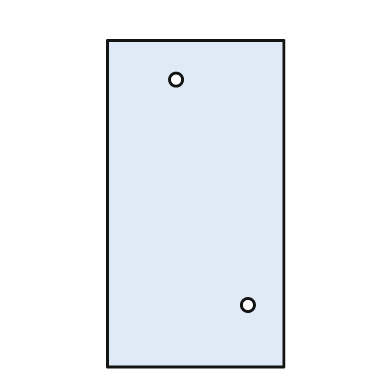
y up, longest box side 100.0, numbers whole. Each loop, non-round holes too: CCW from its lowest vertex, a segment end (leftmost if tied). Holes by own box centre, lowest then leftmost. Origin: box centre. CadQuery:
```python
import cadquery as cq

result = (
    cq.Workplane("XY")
    .moveTo(-27.0, -50.0)
    .lineTo(27.0, -50.0)
    .lineTo(27.0, 50.0)
    .lineTo(-27.0, 50.0)
    .close()
    .moveTo(16.0, -31.0)
    .circle(2.0)
    .moveTo(-6.0, 38.0)
    .circle(2.0)
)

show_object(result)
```